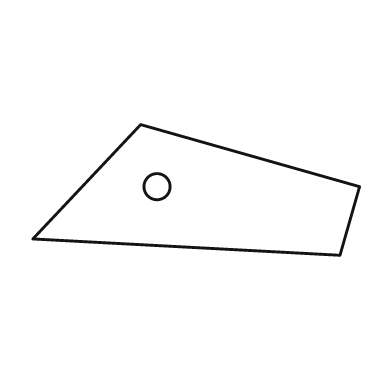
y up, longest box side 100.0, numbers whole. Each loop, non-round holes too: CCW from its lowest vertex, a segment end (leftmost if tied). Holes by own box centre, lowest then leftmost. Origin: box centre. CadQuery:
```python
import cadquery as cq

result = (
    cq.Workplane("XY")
    .moveTo(44.0, -20.0)
    .lineTo(50.0, 1.0)
    .lineTo(-17.0, 20.0)
    .lineTo(-50.0, -15.0)
    .close()
    .moveTo(-12.0, 1.0)
    .circle(4.0)
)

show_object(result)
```